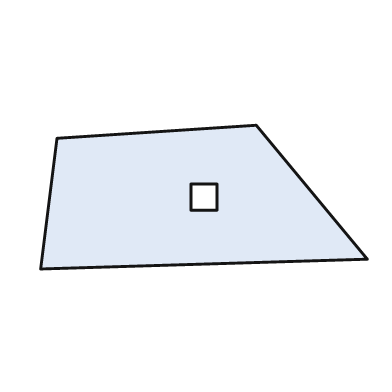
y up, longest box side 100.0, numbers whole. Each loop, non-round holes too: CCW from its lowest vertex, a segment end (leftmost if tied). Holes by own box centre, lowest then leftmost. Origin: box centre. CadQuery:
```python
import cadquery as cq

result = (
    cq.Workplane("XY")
    .moveTo(-50.0, -22.0)
    .lineTo(50.0, -19.0)
    .lineTo(16.0, 22.0)
    .lineTo(-45.0, 18.0)
    .close()
    .moveTo(-4.0, -4.0)
    .lineTo(4.0, -4.0)
    .lineTo(4.0, 4.0)
    .lineTo(-4.0, 4.0)
    .close()
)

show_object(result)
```